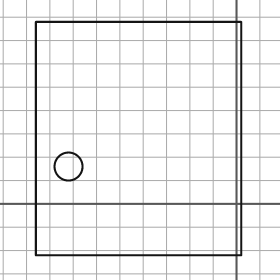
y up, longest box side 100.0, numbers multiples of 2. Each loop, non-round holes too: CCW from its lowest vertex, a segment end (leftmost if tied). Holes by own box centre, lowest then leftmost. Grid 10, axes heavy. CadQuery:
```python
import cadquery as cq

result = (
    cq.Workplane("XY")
    .moveTo(-86.0, -22.0)
    .lineTo(2.0, -22.0)
    .lineTo(2.0, 78.0)
    .lineTo(-86.0, 78.0)
    .close()
    .moveTo(-72.0, 16.0)
    .circle(6.0)
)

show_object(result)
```